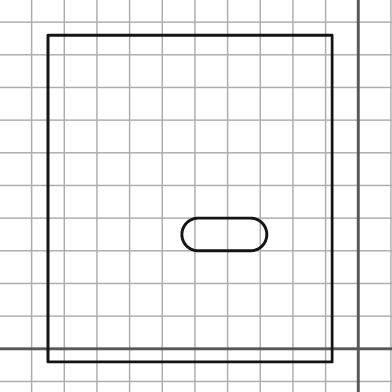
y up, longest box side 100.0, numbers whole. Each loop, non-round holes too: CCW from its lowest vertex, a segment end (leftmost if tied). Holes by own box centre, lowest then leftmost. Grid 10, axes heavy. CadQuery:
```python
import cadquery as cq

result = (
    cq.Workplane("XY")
    .moveTo(-95.0, -4.0)
    .lineTo(-8.0, -4.0)
    .lineTo(-8.0, 96.0)
    .lineTo(-95.0, 96.0)
    .close()
    .moveTo(-49.0, 30.0)
    .lineTo(-33.0, 30.0)
    .threePointArc((-28.0, 35.0), (-33.0, 40.0))
    .lineTo(-49.0, 40.0)
    .threePointArc((-54.0, 35.0), (-49.0, 30.0))
    .close()
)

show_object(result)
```